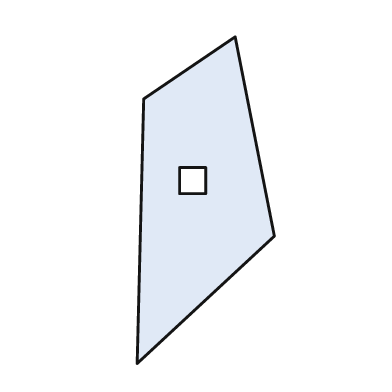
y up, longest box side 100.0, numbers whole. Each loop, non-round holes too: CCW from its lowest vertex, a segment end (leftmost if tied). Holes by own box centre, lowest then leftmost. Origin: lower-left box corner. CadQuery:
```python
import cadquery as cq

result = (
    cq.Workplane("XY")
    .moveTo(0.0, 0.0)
    .lineTo(42.0, 39.0)
    .lineTo(30.0, 100.0)
    .lineTo(2.0, 81.0)
    .close()
    .moveTo(13.0, 52.0)
    .lineTo(21.0, 52.0)
    .lineTo(21.0, 60.0)
    .lineTo(13.0, 60.0)
    .close()
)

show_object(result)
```